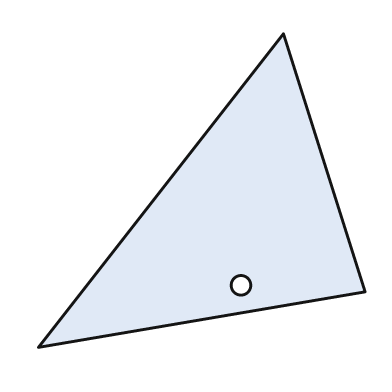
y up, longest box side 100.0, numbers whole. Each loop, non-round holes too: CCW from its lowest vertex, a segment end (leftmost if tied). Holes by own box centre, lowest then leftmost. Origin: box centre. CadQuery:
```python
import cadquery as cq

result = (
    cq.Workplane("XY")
    .moveTo(-50.0, -48.0)
    .lineTo(50.0, -31.0)
    .lineTo(25.0, 48.0)
    .close()
    .moveTo(12.0, -29.0)
    .circle(3.0)
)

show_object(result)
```